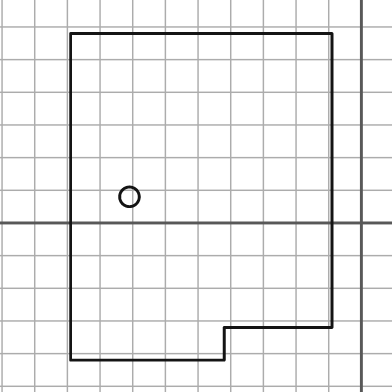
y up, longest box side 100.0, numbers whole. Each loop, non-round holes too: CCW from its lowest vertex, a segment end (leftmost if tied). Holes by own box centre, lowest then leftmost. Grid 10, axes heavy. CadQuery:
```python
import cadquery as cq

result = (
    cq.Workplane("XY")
    .moveTo(-89.0, -42.0)
    .lineTo(-42.0, -42.0)
    .lineTo(-42.0, -32.0)
    .lineTo(-9.0, -32.0)
    .lineTo(-9.0, 58.0)
    .lineTo(-89.0, 58.0)
    .close()
    .moveTo(-71.0, 8.0)
    .circle(3.0)
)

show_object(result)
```